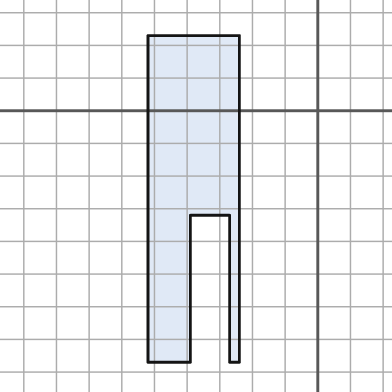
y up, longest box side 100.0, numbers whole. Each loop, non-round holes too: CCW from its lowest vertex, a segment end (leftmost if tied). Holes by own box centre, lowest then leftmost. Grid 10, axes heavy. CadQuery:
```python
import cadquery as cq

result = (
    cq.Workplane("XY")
    .moveTo(-52.0, -77.0)
    .lineTo(-39.0, -77.0)
    .lineTo(-39.0, -32.0)
    .lineTo(-27.0, -32.0)
    .lineTo(-27.0, -77.0)
    .lineTo(-24.0, -77.0)
    .lineTo(-24.0, 23.0)
    .lineTo(-52.0, 23.0)
    .close()
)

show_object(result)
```